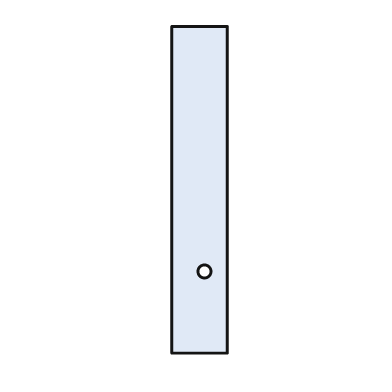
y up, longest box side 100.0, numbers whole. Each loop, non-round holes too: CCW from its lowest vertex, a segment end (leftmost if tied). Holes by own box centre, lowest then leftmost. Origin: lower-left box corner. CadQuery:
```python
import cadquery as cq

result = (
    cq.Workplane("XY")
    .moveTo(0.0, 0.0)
    .lineTo(17.0, 0.0)
    .lineTo(17.0, 100.0)
    .lineTo(0.0, 100.0)
    .close()
    .moveTo(10.0, 25.0)
    .circle(2.0)
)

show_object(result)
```